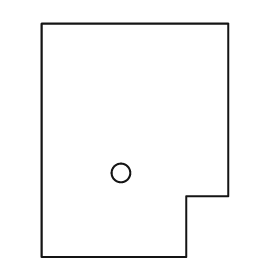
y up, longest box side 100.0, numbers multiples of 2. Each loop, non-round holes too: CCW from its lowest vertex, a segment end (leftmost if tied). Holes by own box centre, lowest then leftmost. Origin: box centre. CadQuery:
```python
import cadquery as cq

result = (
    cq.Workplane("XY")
    .moveTo(-40.0, -50.0)
    .lineTo(22.0, -50.0)
    .lineTo(22.0, -24.0)
    .lineTo(40.0, -24.0)
    .lineTo(40.0, 50.0)
    .lineTo(-40.0, 50.0)
    .close()
    .moveTo(-6.0, -14.0)
    .circle(4.0)
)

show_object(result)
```